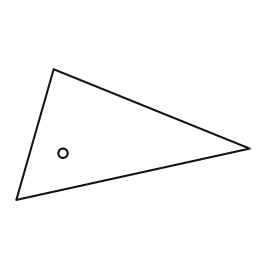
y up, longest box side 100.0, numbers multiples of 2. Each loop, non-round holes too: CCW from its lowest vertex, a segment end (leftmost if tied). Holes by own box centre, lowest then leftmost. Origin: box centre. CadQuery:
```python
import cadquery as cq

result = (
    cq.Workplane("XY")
    .moveTo(-50.0, -28.0)
    .lineTo(50.0, -6.0)
    .lineTo(-34.0, 28.0)
    .close()
    .moveTo(-30.0, -8.0)
    .circle(2.0)
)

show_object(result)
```